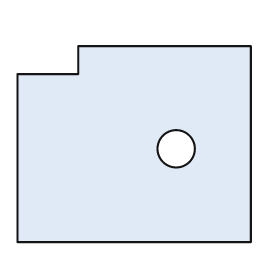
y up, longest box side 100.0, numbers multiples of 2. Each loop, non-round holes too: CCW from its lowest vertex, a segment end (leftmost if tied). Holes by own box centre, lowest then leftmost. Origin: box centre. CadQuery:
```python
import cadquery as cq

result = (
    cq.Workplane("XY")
    .moveTo(-50.0, -42.0)
    .lineTo(50.0, -42.0)
    .lineTo(50.0, 42.0)
    .lineTo(-24.0, 42.0)
    .lineTo(-24.0, 30.0)
    .lineTo(-50.0, 30.0)
    .close()
    .moveTo(18.0, -2.0)
    .circle(8.0)
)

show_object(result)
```